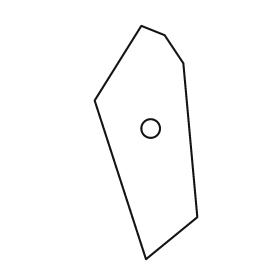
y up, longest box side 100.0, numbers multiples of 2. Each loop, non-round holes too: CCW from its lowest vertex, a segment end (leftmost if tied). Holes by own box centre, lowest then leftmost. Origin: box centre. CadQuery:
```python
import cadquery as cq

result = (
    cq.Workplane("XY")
    .moveTo(0.0, -50.0)
    .lineTo(22.0, -32.0)
    .lineTo(16.0, 34.0)
    .lineTo(8.0, 46.0)
    .lineTo(-2.0, 50.0)
    .lineTo(-22.0, 18.0)
    .close()
    .moveTo(2.0, 6.0)
    .circle(4.0)
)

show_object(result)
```